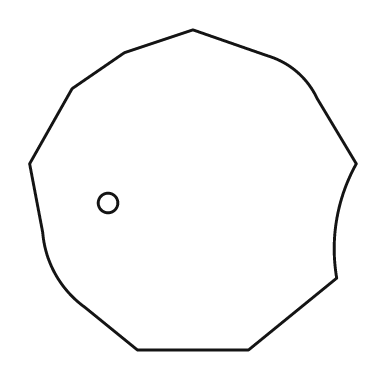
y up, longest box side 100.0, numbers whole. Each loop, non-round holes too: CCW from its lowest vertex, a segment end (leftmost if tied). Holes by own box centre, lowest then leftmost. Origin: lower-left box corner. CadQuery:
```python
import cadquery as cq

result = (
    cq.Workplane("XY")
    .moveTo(33.0, 0.0)
    .lineTo(67.0, 0.0)
    .lineTo(94.0, 22.0)
    .threePointArc((94.0, 40.0), (100.0, 57.0))
    .lineTo(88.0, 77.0)
    .threePointArc((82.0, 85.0), (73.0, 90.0))
    .lineTo(50.0, 98.0)
    .lineTo(29.0, 91.0)
    .lineTo(13.0, 80.0)
    .lineTo(0.0, 57.0)
    .lineTo(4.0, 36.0)
    .threePointArc((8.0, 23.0), (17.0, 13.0))
    .close()
    .moveTo(24.0, 45.0)
    .circle(3.0)
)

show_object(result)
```